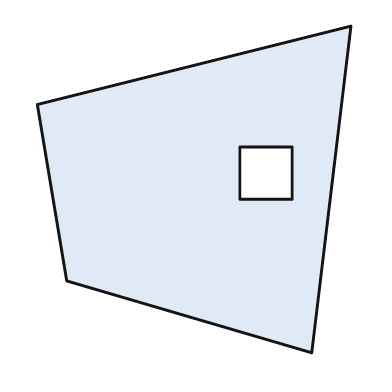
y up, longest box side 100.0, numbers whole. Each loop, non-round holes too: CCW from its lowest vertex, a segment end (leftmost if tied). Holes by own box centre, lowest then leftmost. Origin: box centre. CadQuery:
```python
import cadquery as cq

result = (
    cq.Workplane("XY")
    .moveTo(36.0, -50.0)
    .lineTo(48.0, 50.0)
    .lineTo(-48.0, 26.0)
    .lineTo(-39.0, -28.0)
    .close()
    .moveTo(14.0, -3.0)
    .lineTo(30.0, -3.0)
    .lineTo(30.0, 13.0)
    .lineTo(14.0, 13.0)
    .close()
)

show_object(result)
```